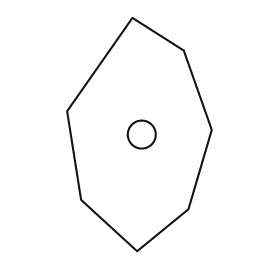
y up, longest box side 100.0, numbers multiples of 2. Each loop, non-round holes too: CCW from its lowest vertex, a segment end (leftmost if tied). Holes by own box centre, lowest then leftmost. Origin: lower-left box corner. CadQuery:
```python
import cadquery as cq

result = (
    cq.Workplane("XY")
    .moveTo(30.0, 0.0)
    .lineTo(52.0, 18.0)
    .lineTo(62.0, 52.0)
    .lineTo(50.0, 86.0)
    .lineTo(28.0, 100.0)
    .lineTo(0.0, 60.0)
    .lineTo(6.0, 22.0)
    .close()
    .moveTo(32.0, 50.0)
    .circle(6.0)
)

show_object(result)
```